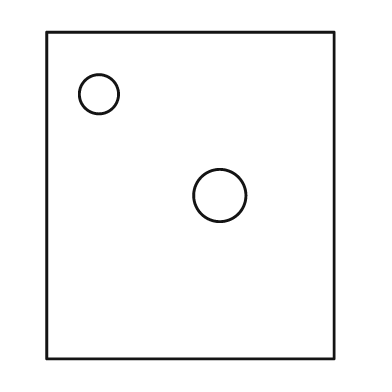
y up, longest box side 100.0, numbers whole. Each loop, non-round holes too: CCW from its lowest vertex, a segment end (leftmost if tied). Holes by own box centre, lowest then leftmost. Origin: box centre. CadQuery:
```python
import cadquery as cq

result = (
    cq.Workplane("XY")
    .moveTo(-44.0, -50.0)
    .lineTo(44.0, -50.0)
    .lineTo(44.0, 50.0)
    .lineTo(-44.0, 50.0)
    .close()
    .moveTo(9.0, 0.0)
    .circle(8.0)
    .moveTo(-28.0, 31.0)
    .circle(6.0)
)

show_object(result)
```